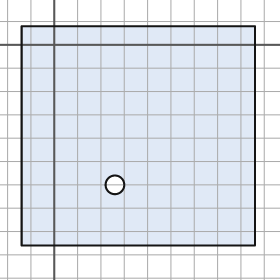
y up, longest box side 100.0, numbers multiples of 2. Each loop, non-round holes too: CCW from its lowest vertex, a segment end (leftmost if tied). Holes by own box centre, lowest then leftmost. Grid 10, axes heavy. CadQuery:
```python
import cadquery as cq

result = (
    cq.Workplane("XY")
    .moveTo(-14.0, -86.0)
    .lineTo(86.0, -86.0)
    .lineTo(86.0, 8.0)
    .lineTo(-14.0, 8.0)
    .close()
    .moveTo(26.0, -60.0)
    .circle(4.0)
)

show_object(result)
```